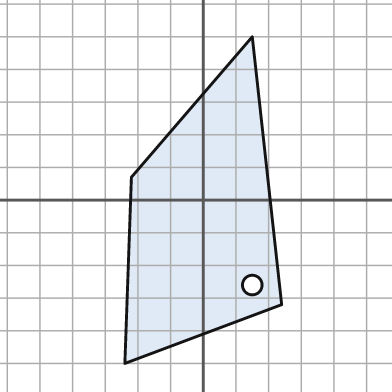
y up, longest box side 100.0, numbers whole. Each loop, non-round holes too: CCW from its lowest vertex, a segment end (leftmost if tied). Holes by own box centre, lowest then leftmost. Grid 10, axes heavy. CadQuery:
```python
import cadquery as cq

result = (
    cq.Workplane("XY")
    .moveTo(-24.0, -50.0)
    .lineTo(24.0, -32.0)
    .lineTo(15.0, 50.0)
    .lineTo(-22.0, 7.0)
    .close()
    .moveTo(15.0, -26.0)
    .circle(3.0)
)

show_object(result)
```